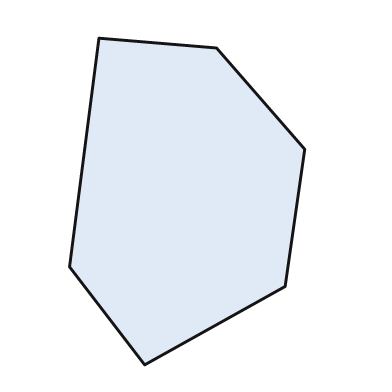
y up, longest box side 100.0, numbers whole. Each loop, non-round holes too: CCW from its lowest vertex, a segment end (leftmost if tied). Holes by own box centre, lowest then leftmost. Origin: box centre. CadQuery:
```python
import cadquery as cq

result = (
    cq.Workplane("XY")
    .moveTo(-13.0, -50.0)
    .lineTo(30.0, -26.0)
    .lineTo(36.0, 16.0)
    .lineTo(9.0, 47.0)
    .lineTo(-27.0, 50.0)
    .lineTo(-36.0, -20.0)
    .close()
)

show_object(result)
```